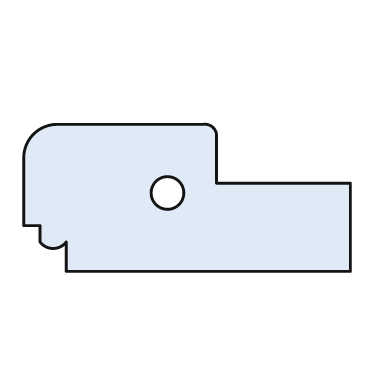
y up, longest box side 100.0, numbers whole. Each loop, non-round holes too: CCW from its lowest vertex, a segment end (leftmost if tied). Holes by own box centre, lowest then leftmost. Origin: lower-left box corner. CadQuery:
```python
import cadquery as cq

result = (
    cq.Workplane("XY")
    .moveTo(13.0, 0.0)
    .lineTo(100.0, 0.0)
    .lineTo(100.0, 27.0)
    .lineTo(59.0, 27.0)
    .lineTo(59.0, 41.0)
    .threePointArc((58.0, 44.0), (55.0, 45.0))
    .lineTo(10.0, 45.0)
    .threePointArc((3.0, 42.0), (0.0, 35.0))
    .lineTo(0.0, 14.0)
    .lineTo(5.0, 14.0)
    .lineTo(5.0, 9.0)
    .threePointArc((9.0, 7.0), (13.0, 9.0))
    .close()
    .moveTo(44.0, 24.0)
    .circle(5.0)
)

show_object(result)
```